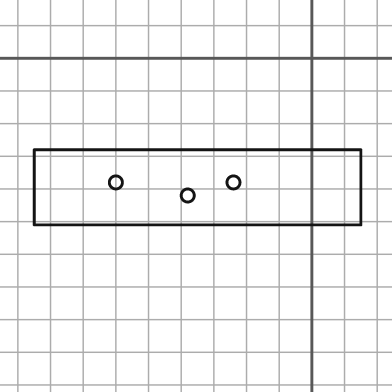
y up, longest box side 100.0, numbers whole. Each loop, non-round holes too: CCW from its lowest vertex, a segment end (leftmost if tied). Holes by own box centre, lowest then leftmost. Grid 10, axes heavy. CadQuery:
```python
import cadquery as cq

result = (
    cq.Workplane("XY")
    .moveTo(-85.0, -51.0)
    .lineTo(15.0, -51.0)
    .lineTo(15.0, -28.0)
    .lineTo(-85.0, -28.0)
    .close()
    .moveTo(-38.0, -42.0)
    .circle(2.0)
    .moveTo(-60.0, -38.0)
    .circle(2.0)
    .moveTo(-24.0, -38.0)
    .circle(2.0)
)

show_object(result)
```